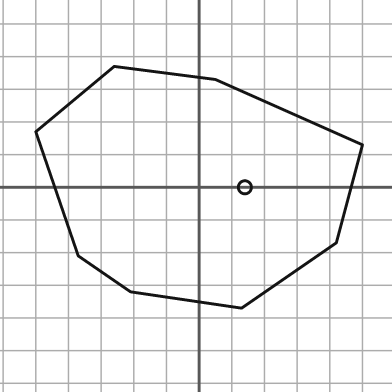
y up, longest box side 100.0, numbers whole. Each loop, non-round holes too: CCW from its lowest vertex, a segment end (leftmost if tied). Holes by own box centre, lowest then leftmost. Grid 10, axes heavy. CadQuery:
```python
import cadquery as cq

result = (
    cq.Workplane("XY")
    .moveTo(13.0, -37.0)
    .lineTo(42.0, -17.0)
    .lineTo(50.0, 13.0)
    .lineTo(5.0, 33.0)
    .lineTo(-26.0, 37.0)
    .lineTo(-50.0, 17.0)
    .lineTo(-37.0, -21.0)
    .lineTo(-21.0, -32.0)
    .close()
    .moveTo(14.0, 0.0)
    .circle(2.0)
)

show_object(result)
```